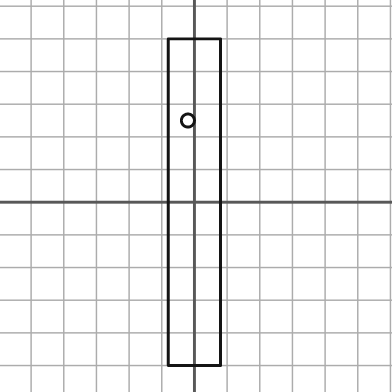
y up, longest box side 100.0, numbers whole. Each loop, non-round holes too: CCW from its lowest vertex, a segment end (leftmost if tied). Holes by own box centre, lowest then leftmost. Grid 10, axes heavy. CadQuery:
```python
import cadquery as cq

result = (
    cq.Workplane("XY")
    .moveTo(-8.0, -50.0)
    .lineTo(8.0, -50.0)
    .lineTo(8.0, 50.0)
    .lineTo(-8.0, 50.0)
    .close()
    .moveTo(-2.0, 25.0)
    .circle(2.0)
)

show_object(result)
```